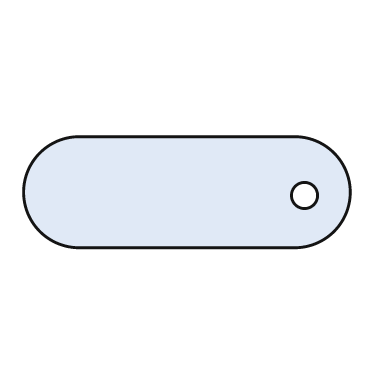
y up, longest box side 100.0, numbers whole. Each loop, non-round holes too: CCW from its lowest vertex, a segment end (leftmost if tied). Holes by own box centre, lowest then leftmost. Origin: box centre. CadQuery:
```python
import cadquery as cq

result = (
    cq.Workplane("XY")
    .moveTo(-33.0, -17.0)
    .lineTo(33.0, -17.0)
    .threePointArc((50.0, 0.0), (33.0, 17.0))
    .lineTo(-33.0, 17.0)
    .threePointArc((-50.0, 0.0), (-33.0, -17.0))
    .close()
    .moveTo(36.0, -1.0)
    .circle(4.0)
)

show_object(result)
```